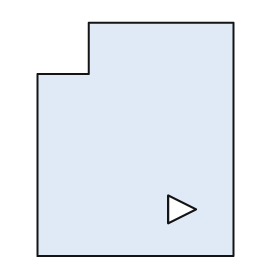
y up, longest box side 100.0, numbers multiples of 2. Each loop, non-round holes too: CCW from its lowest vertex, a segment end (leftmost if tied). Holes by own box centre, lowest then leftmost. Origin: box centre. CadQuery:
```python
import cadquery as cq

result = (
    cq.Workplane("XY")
    .moveTo(-42.0, -50.0)
    .lineTo(42.0, -50.0)
    .lineTo(42.0, 50.0)
    .lineTo(-20.0, 50.0)
    .lineTo(-20.0, 28.0)
    .lineTo(-42.0, 28.0)
    .close()
    .moveTo(14.0, -36.0)
    .lineTo(26.0, -30.0)
    .lineTo(14.0, -24.0)
    .close()
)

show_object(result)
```